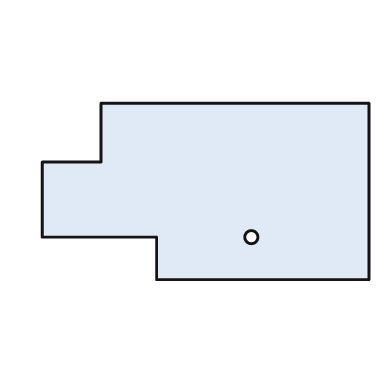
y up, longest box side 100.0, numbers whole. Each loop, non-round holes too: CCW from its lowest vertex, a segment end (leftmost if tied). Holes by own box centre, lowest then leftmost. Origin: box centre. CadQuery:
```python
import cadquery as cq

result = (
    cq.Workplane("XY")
    .moveTo(-15.0, -27.0)
    .lineTo(50.0, -27.0)
    .lineTo(50.0, 27.0)
    .lineTo(-32.0, 27.0)
    .lineTo(-32.0, 9.0)
    .lineTo(-50.0, 9.0)
    .lineTo(-50.0, -14.0)
    .lineTo(-15.0, -14.0)
    .close()
    .moveTo(14.0, -14.0)
    .circle(2.0)
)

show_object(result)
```